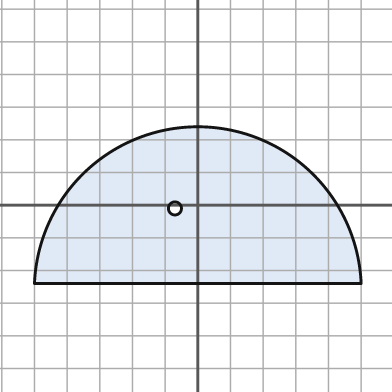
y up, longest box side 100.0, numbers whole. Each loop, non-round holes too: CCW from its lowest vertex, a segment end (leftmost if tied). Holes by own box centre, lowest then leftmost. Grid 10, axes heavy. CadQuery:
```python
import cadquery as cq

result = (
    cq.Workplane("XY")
    .moveTo(-50.0, -24.0)
    .lineTo(50.0, -24.0)
    .threePointArc((0.0, 24.0), (-50.0, -24.0))
    .close()
    .moveTo(-7.0, -1.0)
    .circle(2.0)
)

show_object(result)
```